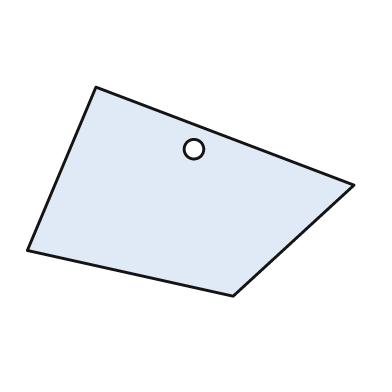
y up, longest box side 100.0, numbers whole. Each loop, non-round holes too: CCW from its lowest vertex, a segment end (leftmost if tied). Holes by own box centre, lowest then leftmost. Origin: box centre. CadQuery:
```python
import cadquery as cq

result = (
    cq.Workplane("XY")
    .moveTo(13.0, -32.0)
    .lineTo(50.0, 2.0)
    .lineTo(-29.0, 32.0)
    .lineTo(-50.0, -18.0)
    .close()
    .moveTo(1.0, 13.0)
    .circle(3.0)
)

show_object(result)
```